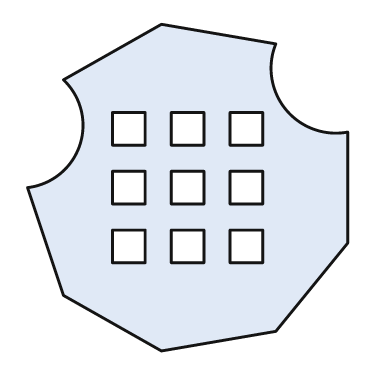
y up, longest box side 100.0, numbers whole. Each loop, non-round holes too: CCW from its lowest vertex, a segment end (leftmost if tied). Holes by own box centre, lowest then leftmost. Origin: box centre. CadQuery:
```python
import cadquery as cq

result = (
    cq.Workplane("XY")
    .moveTo(-8.0, -50.0)
    .lineTo(27.0, -44.0)
    .lineTo(49.0, -17.0)
    .lineTo(49.0, 17.0)
    .threePointArc((30.0, 24.0), (27.0, 44.0))
    .lineTo(-8.0, 50.0)
    .lineTo(-38.0, 33.0)
    .threePointArc((-33.0, 13.0), (-49.0, 0.0))
    .lineTo(-38.0, -33.0)
    .close()
    .moveTo(-23.0, -23.0)
    .lineTo(-13.0, -23.0)
    .lineTo(-13.0, -13.0)
    .lineTo(-23.0, -13.0)
    .close()
    .moveTo(-5.0, -23.0)
    .lineTo(5.0, -23.0)
    .lineTo(5.0, -13.0)
    .lineTo(-5.0, -13.0)
    .close()
    .moveTo(13.0, -23.0)
    .lineTo(23.0, -23.0)
    .lineTo(23.0, -13.0)
    .lineTo(13.0, -13.0)
    .close()
    .moveTo(-23.0, -5.0)
    .lineTo(-13.0, -5.0)
    .lineTo(-13.0, 5.0)
    .lineTo(-23.0, 5.0)
    .close()
    .moveTo(-5.0, -5.0)
    .lineTo(5.0, -5.0)
    .lineTo(5.0, 5.0)
    .lineTo(-5.0, 5.0)
    .close()
    .moveTo(13.0, -5.0)
    .lineTo(23.0, -5.0)
    .lineTo(23.0, 5.0)
    .lineTo(13.0, 5.0)
    .close()
    .moveTo(-23.0, 13.0)
    .lineTo(-13.0, 13.0)
    .lineTo(-13.0, 23.0)
    .lineTo(-23.0, 23.0)
    .close()
    .moveTo(-5.0, 13.0)
    .lineTo(5.0, 13.0)
    .lineTo(5.0, 23.0)
    .lineTo(-5.0, 23.0)
    .close()
    .moveTo(13.0, 13.0)
    .lineTo(23.0, 13.0)
    .lineTo(23.0, 23.0)
    .lineTo(13.0, 23.0)
    .close()
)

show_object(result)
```